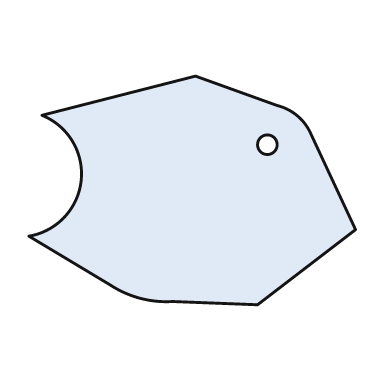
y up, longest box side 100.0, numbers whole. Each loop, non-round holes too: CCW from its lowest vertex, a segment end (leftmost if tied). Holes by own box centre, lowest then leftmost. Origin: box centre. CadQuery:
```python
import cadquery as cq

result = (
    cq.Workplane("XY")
    .moveTo(20.0, -35.0)
    .lineTo(50.0, -12.0)
    .lineTo(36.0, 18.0)
    .threePointArc((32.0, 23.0), (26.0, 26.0))
    .lineTo(1.0, 35.0)
    .lineTo(-46.0, 23.0)
    .threePointArc((-34.0, 3.0), (-50.0, -14.0))
    .lineTo(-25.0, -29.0)
    .threePointArc((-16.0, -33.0), (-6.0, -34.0))
    .close()
    .moveTo(23.0, 14.0)
    .circle(3.0)
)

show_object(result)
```